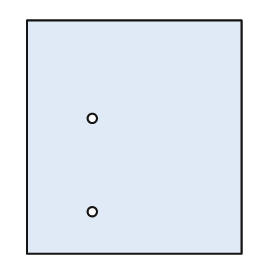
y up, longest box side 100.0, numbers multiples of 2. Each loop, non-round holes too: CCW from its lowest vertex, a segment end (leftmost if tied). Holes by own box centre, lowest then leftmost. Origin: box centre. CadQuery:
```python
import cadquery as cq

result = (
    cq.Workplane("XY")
    .moveTo(-46.0, -50.0)
    .lineTo(46.0, -50.0)
    .lineTo(46.0, 50.0)
    .lineTo(-46.0, 50.0)
    .close()
    .moveTo(-18.0, -32.0)
    .circle(2.0)
    .moveTo(-18.0, 8.0)
    .circle(2.0)
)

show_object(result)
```